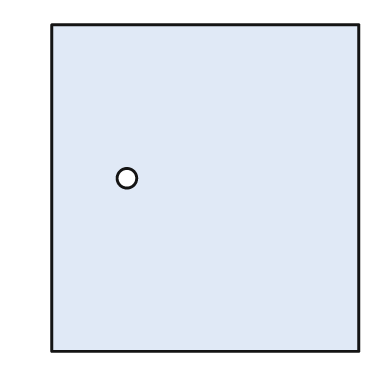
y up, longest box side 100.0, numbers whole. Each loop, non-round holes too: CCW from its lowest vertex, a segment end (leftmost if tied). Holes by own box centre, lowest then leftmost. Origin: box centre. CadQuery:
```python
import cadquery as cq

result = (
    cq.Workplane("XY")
    .moveTo(-47.0, -50.0)
    .lineTo(47.0, -50.0)
    .lineTo(47.0, 50.0)
    .lineTo(-47.0, 50.0)
    .close()
    .moveTo(-24.0, 3.0)
    .circle(3.0)
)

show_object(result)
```